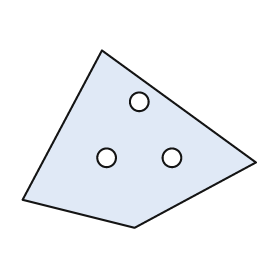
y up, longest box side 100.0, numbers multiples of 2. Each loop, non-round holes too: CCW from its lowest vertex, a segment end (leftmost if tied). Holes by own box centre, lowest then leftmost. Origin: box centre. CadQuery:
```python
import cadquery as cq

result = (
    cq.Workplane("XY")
    .moveTo(-2.0, -38.0)
    .lineTo(50.0, -10.0)
    .lineTo(-16.0, 38.0)
    .lineTo(-50.0, -26.0)
    .close()
    .moveTo(-14.0, -8.0)
    .circle(4.0)
    .moveTo(14.0, -8.0)
    .circle(4.0)
    .moveTo(0.0, 16.0)
    .circle(4.0)
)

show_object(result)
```